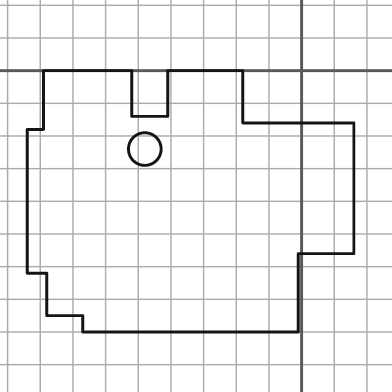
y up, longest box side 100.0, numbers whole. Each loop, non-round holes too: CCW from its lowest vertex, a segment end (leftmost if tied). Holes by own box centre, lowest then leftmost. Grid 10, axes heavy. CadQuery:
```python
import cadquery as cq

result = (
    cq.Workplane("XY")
    .moveTo(-67.0, -80.0)
    .lineTo(-1.0, -80.0)
    .lineTo(-1.0, -56.0)
    .lineTo(16.0, -56.0)
    .lineTo(16.0, -16.0)
    .lineTo(-18.0, -16.0)
    .lineTo(-18.0, 0.0)
    .lineTo(-41.0, 0.0)
    .lineTo(-41.0, -14.0)
    .lineTo(-52.0, -14.0)
    .lineTo(-52.0, 0.0)
    .lineTo(-79.0, 0.0)
    .lineTo(-79.0, -18.0)
    .lineTo(-84.0, -18.0)
    .lineTo(-84.0, -62.0)
    .lineTo(-78.0, -62.0)
    .lineTo(-78.0, -75.0)
    .lineTo(-67.0, -75.0)
    .close()
    .moveTo(-48.0, -24.0)
    .circle(5.0)
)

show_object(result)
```